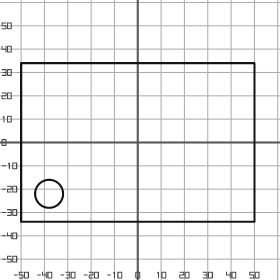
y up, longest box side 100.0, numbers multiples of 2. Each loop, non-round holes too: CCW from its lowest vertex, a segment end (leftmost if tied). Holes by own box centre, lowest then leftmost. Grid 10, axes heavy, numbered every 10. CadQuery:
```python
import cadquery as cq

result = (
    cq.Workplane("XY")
    .moveTo(-50.0, -34.0)
    .lineTo(50.0, -34.0)
    .lineTo(50.0, 34.0)
    .lineTo(-50.0, 34.0)
    .close()
    .moveTo(-38.0, -22.0)
    .circle(6.0)
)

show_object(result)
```